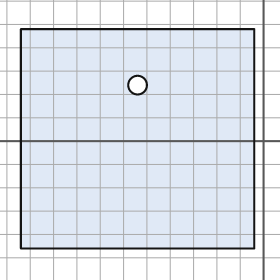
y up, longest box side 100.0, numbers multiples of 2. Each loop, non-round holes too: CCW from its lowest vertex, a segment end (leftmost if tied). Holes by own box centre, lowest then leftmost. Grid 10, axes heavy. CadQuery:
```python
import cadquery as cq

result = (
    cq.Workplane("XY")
    .moveTo(-104.0, -46.0)
    .lineTo(-4.0, -46.0)
    .lineTo(-4.0, 48.0)
    .lineTo(-104.0, 48.0)
    .close()
    .moveTo(-54.0, 24.0)
    .circle(4.0)
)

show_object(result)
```